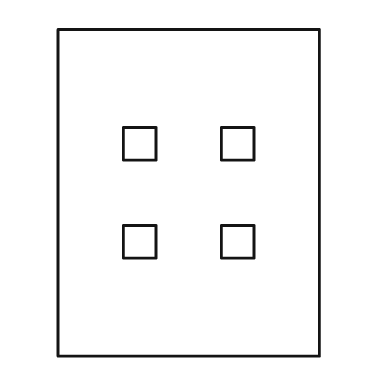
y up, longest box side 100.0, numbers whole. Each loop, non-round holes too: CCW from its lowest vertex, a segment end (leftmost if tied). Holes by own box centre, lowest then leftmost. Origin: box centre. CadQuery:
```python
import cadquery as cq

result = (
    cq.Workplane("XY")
    .moveTo(-40.0, -50.0)
    .lineTo(40.0, -50.0)
    .lineTo(40.0, 50.0)
    .lineTo(-40.0, 50.0)
    .close()
    .moveTo(-20.0, -20.0)
    .lineTo(-10.0, -20.0)
    .lineTo(-10.0, -10.0)
    .lineTo(-20.0, -10.0)
    .close()
    .moveTo(10.0, -20.0)
    .lineTo(20.0, -20.0)
    .lineTo(20.0, -10.0)
    .lineTo(10.0, -10.0)
    .close()
    .moveTo(-20.0, 10.0)
    .lineTo(-10.0, 10.0)
    .lineTo(-10.0, 20.0)
    .lineTo(-20.0, 20.0)
    .close()
    .moveTo(10.0, 10.0)
    .lineTo(20.0, 10.0)
    .lineTo(20.0, 20.0)
    .lineTo(10.0, 20.0)
    .close()
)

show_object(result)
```